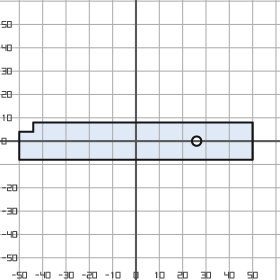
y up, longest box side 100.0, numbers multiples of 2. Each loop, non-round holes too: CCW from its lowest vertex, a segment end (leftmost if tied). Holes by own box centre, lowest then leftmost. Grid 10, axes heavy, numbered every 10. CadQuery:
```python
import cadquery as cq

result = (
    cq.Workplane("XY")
    .moveTo(-50.0, -8.0)
    .lineTo(50.0, -8.0)
    .lineTo(50.0, 8.0)
    .lineTo(-44.0, 8.0)
    .lineTo(-44.0, 4.0)
    .lineTo(-50.0, 4.0)
    .close()
    .moveTo(26.0, 0.0)
    .circle(2.0)
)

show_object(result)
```